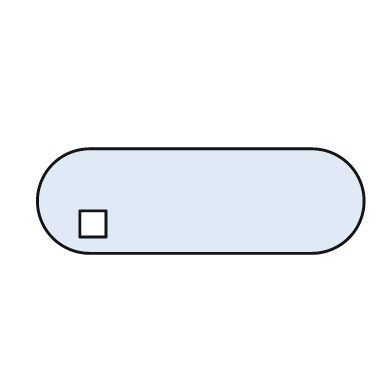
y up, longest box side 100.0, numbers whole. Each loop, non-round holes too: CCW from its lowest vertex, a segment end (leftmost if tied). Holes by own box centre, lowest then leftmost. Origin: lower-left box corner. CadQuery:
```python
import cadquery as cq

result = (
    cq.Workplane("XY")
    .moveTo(16.0, 0.0)
    .lineTo(84.0, 0.0)
    .threePointArc((100.0, 16.0), (84.0, 32.0))
    .lineTo(16.0, 32.0)
    .threePointArc((0.0, 16.0), (16.0, 0.0))
    .close()
    .moveTo(13.0, 5.0)
    .lineTo(21.0, 5.0)
    .lineTo(21.0, 13.0)
    .lineTo(13.0, 13.0)
    .close()
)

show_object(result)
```